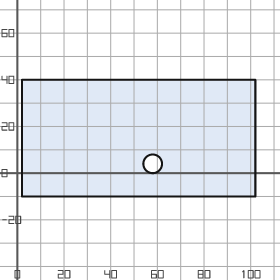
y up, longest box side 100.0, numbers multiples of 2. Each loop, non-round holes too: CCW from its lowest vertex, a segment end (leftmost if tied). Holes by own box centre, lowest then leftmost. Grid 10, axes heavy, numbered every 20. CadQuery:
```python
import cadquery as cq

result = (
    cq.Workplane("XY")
    .moveTo(2.0, -10.0)
    .lineTo(102.0, -10.0)
    .lineTo(102.0, 40.0)
    .lineTo(2.0, 40.0)
    .close()
    .moveTo(58.0, 4.0)
    .circle(4.0)
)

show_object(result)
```